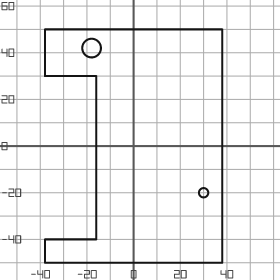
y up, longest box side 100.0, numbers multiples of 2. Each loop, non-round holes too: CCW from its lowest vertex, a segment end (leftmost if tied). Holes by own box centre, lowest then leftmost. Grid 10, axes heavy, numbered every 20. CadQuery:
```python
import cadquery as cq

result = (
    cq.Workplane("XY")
    .moveTo(-38.0, -50.0)
    .lineTo(38.0, -50.0)
    .lineTo(38.0, 50.0)
    .lineTo(-38.0, 50.0)
    .lineTo(-38.0, 30.0)
    .lineTo(-16.0, 30.0)
    .lineTo(-16.0, -40.0)
    .lineTo(-38.0, -40.0)
    .close()
    .moveTo(30.0, -20.0)
    .circle(2.0)
    .moveTo(-18.0, 42.0)
    .circle(4.0)
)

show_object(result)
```